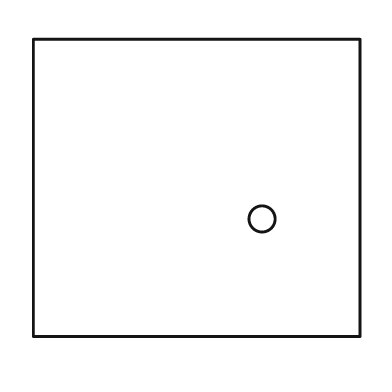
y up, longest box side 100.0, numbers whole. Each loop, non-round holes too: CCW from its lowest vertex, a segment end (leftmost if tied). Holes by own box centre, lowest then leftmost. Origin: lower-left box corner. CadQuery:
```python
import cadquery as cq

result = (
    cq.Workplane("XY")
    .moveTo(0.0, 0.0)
    .lineTo(100.0, 0.0)
    .lineTo(100.0, 91.0)
    .lineTo(0.0, 91.0)
    .close()
    .moveTo(70.0, 36.0)
    .circle(4.0)
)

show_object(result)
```